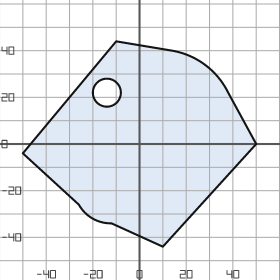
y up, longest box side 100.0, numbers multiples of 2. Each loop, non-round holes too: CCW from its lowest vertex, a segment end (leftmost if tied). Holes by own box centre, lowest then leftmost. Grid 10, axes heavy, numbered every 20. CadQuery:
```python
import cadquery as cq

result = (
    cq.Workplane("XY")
    .moveTo(10.0, -44.0)
    .lineTo(50.0, 0.0)
    .lineTo(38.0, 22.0)
    .threePointArc((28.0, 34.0), (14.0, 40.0))
    .lineTo(-10.0, 44.0)
    .lineTo(-50.0, -4.0)
    .lineTo(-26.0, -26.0)
    .threePointArc((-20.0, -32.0), (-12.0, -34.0))
    .close()
    .moveTo(-14.0, 22.0)
    .circle(6.0)
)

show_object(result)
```